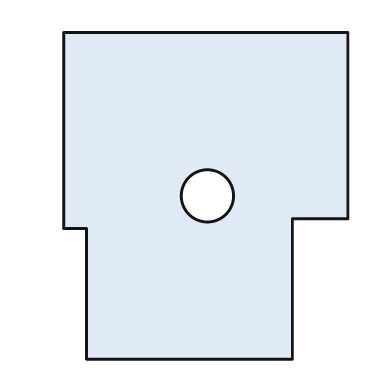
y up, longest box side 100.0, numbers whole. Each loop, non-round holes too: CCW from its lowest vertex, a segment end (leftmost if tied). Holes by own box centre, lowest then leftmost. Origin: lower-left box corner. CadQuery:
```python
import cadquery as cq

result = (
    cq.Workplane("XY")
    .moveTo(7.0, 0.0)
    .lineTo(70.0, 0.0)
    .lineTo(70.0, 43.0)
    .lineTo(87.0, 43.0)
    .lineTo(87.0, 100.0)
    .lineTo(0.0, 100.0)
    .lineTo(0.0, 40.0)
    .lineTo(7.0, 40.0)
    .close()
    .moveTo(44.0, 50.0)
    .circle(8.0)
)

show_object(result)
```